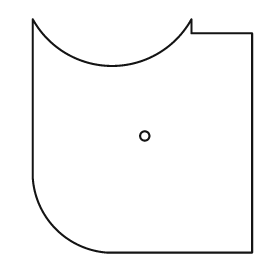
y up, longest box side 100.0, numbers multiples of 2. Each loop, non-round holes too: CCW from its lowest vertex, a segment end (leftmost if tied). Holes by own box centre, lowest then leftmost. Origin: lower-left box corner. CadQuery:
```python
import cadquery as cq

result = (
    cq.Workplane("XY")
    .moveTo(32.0, 0.0)
    .lineTo(94.0, 0.0)
    .lineTo(94.0, 94.0)
    .lineTo(68.0, 94.0)
    .lineTo(68.0, 100.0)
    .threePointArc((34.0, 80.0), (0.0, 100.0))
    .lineTo(0.0, 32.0)
    .threePointArc((10.0, 10.0), (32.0, 0.0))
    .close()
    .moveTo(48.0, 50.0)
    .circle(2.0)
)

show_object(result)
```